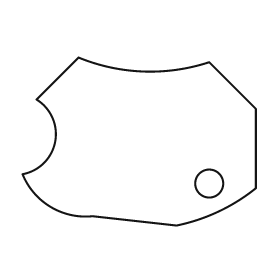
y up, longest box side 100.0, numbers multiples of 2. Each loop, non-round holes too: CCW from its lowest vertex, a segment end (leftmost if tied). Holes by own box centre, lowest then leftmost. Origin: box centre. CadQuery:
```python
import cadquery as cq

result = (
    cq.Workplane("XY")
    .moveTo(16.0, -36.0)
    .threePointArc((34.0, -30.0), (50.0, -20.0))
    .lineTo(50.0, 14.0)
    .lineTo(30.0, 34.0)
    .threePointArc((2.0, 30.0), (-26.0, 36.0))
    .lineTo(-44.0, 18.0)
    .threePointArc((-36.0, 0.0), (-50.0, -14.0))
    .threePointArc((-38.0, -28.0), (-20.0, -32.0))
    .close()
    .moveTo(30.0, -18.0)
    .circle(6.0)
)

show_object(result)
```